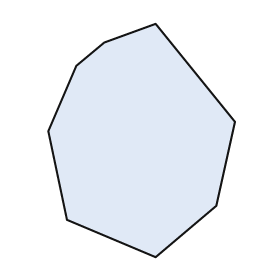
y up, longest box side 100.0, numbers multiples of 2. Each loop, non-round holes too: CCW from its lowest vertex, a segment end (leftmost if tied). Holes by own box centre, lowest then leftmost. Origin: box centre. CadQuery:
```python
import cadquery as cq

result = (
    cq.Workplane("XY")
    .moveTo(6.0, -50.0)
    .lineTo(32.0, -28.0)
    .lineTo(40.0, 8.0)
    .lineTo(6.0, 50.0)
    .lineTo(-16.0, 42.0)
    .lineTo(-28.0, 32.0)
    .lineTo(-40.0, 4.0)
    .lineTo(-32.0, -34.0)
    .close()
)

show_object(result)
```